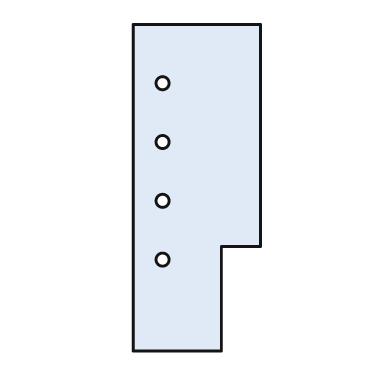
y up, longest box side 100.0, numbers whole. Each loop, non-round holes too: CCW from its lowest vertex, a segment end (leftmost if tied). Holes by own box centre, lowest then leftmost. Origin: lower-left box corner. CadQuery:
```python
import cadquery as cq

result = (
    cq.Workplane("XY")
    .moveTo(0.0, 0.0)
    .lineTo(27.0, 0.0)
    .lineTo(27.0, 32.0)
    .lineTo(39.0, 32.0)
    .lineTo(39.0, 100.0)
    .lineTo(0.0, 100.0)
    .close()
    .moveTo(9.0, 28.0)
    .circle(2.0)
    .moveTo(9.0, 46.0)
    .circle(2.0)
    .moveTo(9.0, 64.0)
    .circle(2.0)
    .moveTo(9.0, 82.0)
    .circle(2.0)
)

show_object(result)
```